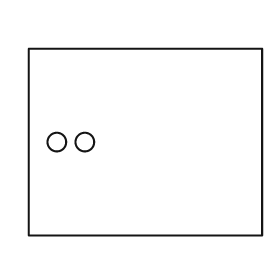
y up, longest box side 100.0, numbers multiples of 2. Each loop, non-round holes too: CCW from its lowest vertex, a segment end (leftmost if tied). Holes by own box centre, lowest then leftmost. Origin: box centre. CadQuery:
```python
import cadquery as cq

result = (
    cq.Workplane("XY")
    .moveTo(-50.0, -40.0)
    .lineTo(50.0, -40.0)
    .lineTo(50.0, 40.0)
    .lineTo(-50.0, 40.0)
    .close()
    .moveTo(-38.0, 0.0)
    .circle(4.0)
    .moveTo(-26.0, 0.0)
    .circle(4.0)
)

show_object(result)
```